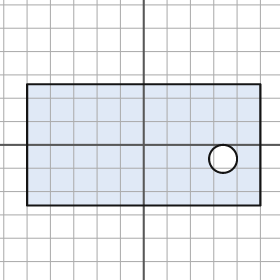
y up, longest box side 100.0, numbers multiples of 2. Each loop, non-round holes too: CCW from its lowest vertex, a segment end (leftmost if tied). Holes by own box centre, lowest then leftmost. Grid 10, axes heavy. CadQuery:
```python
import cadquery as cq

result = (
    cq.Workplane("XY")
    .moveTo(-50.0, -26.0)
    .lineTo(50.0, -26.0)
    .lineTo(50.0, 26.0)
    .lineTo(-50.0, 26.0)
    .close()
    .moveTo(34.0, -6.0)
    .circle(6.0)
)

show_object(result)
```